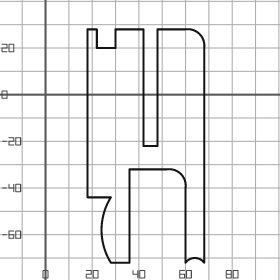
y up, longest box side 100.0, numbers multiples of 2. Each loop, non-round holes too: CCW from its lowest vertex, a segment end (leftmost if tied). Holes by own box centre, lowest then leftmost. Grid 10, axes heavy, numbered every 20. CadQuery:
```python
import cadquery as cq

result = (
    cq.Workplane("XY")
    .moveTo(28.0, -72.0)
    .lineTo(36.0, -72.0)
    .lineTo(36.0, -32.0)
    .lineTo(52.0, -32.0)
    .threePointArc((58.0, -34.0), (60.0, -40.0))
    .lineTo(60.0, -72.0)
    .threePointArc((64.0, -70.0), (68.0, -72.0))
    .lineTo(68.0, 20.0)
    .threePointArc((66.0, 26.0), (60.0, 28.0))
    .lineTo(48.0, 28.0)
    .lineTo(48.0, -22.0)
    .lineTo(42.0, -22.0)
    .lineTo(42.0, 28.0)
    .lineTo(30.0, 28.0)
    .lineTo(30.0, 20.0)
    .lineTo(22.0, 20.0)
    .lineTo(22.0, 28.0)
    .lineTo(18.0, 28.0)
    .lineTo(18.0, -44.0)
    .lineTo(28.0, -44.0)
    .threePointArc((24.0, -58.0), (28.0, -72.0))
    .close()
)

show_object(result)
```